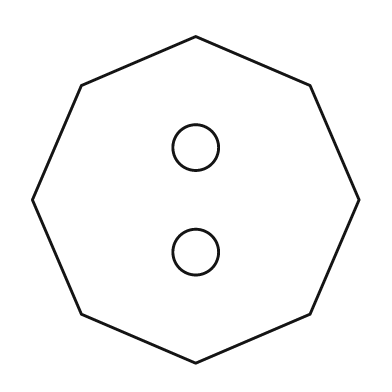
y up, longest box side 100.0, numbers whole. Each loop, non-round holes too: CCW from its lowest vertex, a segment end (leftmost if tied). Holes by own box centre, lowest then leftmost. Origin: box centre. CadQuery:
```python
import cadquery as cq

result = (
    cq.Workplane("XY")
    .moveTo(0.0, -50.0)
    .lineTo(35.0, -35.0)
    .lineTo(50.0, 0.0)
    .lineTo(35.0, 35.0)
    .lineTo(0.0, 50.0)
    .lineTo(-35.0, 35.0)
    .lineTo(-50.0, 0.0)
    .lineTo(-35.0, -35.0)
    .close()
    .moveTo(0.0, -16.0)
    .circle(7.0)
    .moveTo(0.0, 16.0)
    .circle(7.0)
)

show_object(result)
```